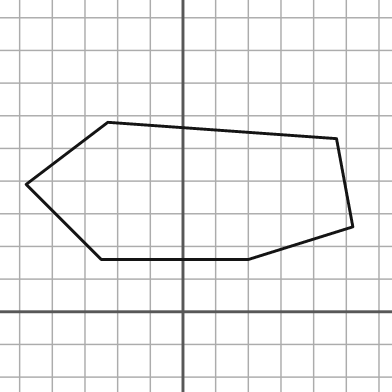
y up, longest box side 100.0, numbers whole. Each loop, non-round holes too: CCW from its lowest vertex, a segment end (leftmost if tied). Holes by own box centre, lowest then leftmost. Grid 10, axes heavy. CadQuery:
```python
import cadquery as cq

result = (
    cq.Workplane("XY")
    .moveTo(-25.0, 16.0)
    .lineTo(20.0, 16.0)
    .lineTo(52.0, 26.0)
    .lineTo(47.0, 53.0)
    .lineTo(-23.0, 58.0)
    .lineTo(-48.0, 39.0)
    .close()
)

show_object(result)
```